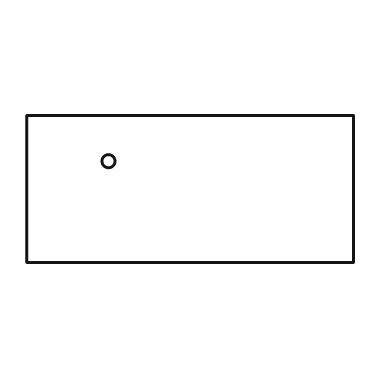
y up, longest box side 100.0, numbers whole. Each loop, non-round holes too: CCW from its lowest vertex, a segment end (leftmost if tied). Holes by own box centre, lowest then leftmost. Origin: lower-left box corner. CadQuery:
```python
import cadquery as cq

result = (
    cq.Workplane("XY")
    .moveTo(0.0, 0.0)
    .lineTo(100.0, 0.0)
    .lineTo(100.0, 45.0)
    .lineTo(0.0, 45.0)
    .close()
    .moveTo(25.0, 31.0)
    .circle(2.0)
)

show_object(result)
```